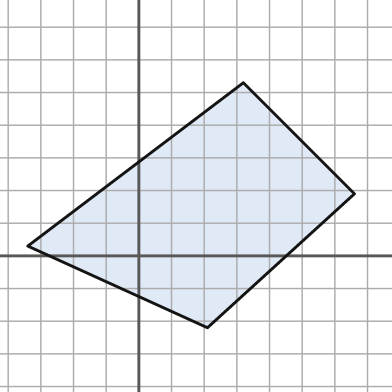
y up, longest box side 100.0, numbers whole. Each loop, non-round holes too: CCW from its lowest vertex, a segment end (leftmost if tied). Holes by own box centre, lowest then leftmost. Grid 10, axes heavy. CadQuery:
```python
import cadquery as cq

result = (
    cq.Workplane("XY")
    .moveTo(21.0, -22.0)
    .lineTo(66.0, 19.0)
    .lineTo(32.0, 53.0)
    .lineTo(-34.0, 3.0)
    .close()
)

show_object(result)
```